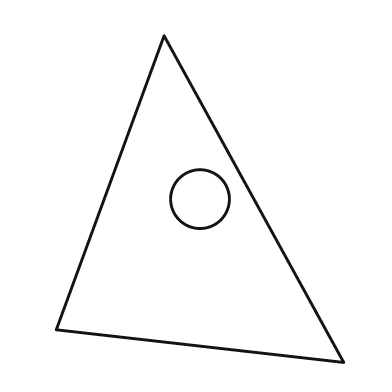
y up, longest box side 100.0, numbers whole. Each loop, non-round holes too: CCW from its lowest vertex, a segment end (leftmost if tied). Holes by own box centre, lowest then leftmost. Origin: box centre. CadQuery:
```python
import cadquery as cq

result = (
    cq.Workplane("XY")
    .moveTo(44.0, -50.0)
    .lineTo(-11.0, 50.0)
    .lineTo(-44.0, -40.0)
    .close()
    .moveTo(0.0, 0.0)
    .circle(9.0)
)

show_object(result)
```